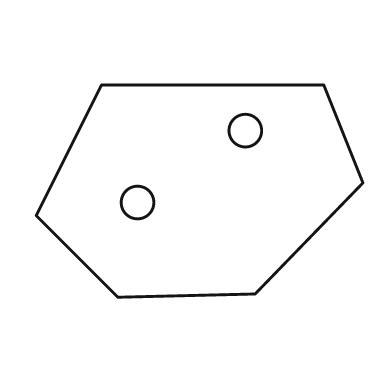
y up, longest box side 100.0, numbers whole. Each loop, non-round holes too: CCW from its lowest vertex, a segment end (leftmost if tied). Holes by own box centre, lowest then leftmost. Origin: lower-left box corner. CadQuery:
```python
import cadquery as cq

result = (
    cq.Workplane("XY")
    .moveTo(25.0, 0.0)
    .lineTo(67.0, 1.0)
    .lineTo(100.0, 35.0)
    .lineTo(88.0, 65.0)
    .lineTo(20.0, 65.0)
    .lineTo(0.0, 25.0)
    .close()
    .moveTo(31.0, 29.0)
    .circle(5.0)
    .moveTo(64.0, 51.0)
    .circle(5.0)
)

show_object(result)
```